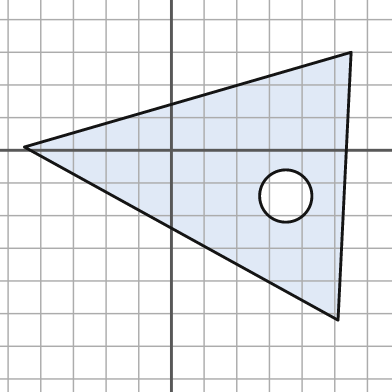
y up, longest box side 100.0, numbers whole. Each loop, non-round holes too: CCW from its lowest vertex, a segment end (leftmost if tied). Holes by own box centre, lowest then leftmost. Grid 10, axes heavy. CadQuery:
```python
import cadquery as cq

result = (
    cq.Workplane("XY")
    .moveTo(51.0, -52.0)
    .lineTo(55.0, 30.0)
    .lineTo(-45.0, 1.0)
    .close()
    .moveTo(35.0, -14.0)
    .circle(8.0)
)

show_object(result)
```